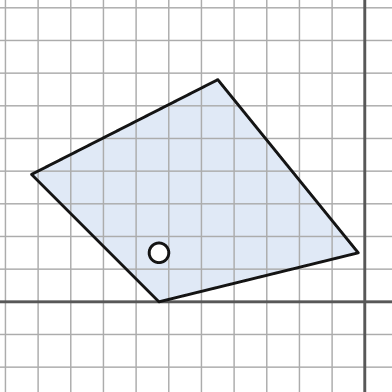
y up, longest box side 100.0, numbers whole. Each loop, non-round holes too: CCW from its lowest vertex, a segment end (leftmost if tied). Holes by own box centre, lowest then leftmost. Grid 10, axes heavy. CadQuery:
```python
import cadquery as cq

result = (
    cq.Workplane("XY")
    .moveTo(-63.0, 0.0)
    .lineTo(-2.0, 15.0)
    .lineTo(-45.0, 68.0)
    .lineTo(-102.0, 39.0)
    .close()
    .moveTo(-63.0, 15.0)
    .circle(3.0)
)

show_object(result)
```